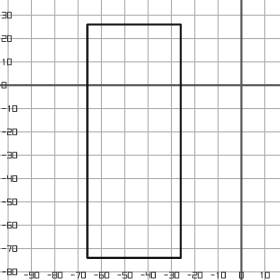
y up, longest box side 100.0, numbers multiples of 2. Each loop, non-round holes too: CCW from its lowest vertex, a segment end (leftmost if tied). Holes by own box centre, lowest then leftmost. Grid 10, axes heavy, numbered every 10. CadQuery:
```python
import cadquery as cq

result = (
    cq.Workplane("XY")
    .moveTo(-66.0, -74.0)
    .lineTo(-26.0, -74.0)
    .lineTo(-26.0, 26.0)
    .lineTo(-66.0, 26.0)
    .close()
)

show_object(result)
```